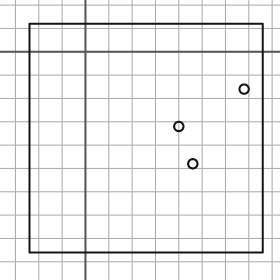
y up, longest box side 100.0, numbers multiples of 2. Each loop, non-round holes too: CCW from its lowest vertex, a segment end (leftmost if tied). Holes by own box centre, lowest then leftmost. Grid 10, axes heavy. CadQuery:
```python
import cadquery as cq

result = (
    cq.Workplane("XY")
    .moveTo(-24.0, -86.0)
    .lineTo(76.0, -86.0)
    .lineTo(76.0, 12.0)
    .lineTo(-24.0, 12.0)
    .close()
    .moveTo(46.0, -48.0)
    .circle(2.0)
    .moveTo(40.0, -32.0)
    .circle(2.0)
    .moveTo(68.0, -16.0)
    .circle(2.0)
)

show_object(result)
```